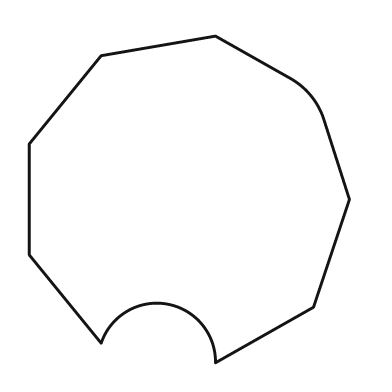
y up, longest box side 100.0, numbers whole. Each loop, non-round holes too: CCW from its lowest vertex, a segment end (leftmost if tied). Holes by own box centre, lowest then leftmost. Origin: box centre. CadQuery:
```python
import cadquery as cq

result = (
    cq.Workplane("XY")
    .moveTo(8.0, -50.0)
    .lineTo(38.0, -33.0)
    .lineTo(49.0, 0.0)
    .lineTo(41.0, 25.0)
    .threePointArc((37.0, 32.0), (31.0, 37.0))
    .lineTo(8.0, 50.0)
    .lineTo(-27.0, 44.0)
    .lineTo(-49.0, 17.0)
    .lineTo(-49.0, -17.0)
    .lineTo(-27.0, -44.0)
    .threePointArc((-7.0, -32.0), (8.0, -50.0))
    .close()
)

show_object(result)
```